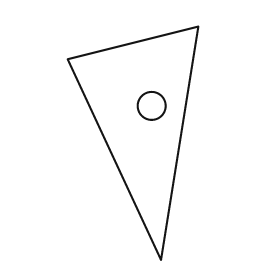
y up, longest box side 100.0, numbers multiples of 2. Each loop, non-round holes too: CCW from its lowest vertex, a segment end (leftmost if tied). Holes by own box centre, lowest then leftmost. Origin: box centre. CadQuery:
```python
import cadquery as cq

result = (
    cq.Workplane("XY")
    .moveTo(12.0, -50.0)
    .lineTo(28.0, 50.0)
    .lineTo(-28.0, 36.0)
    .close()
    .moveTo(8.0, 16.0)
    .circle(6.0)
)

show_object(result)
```